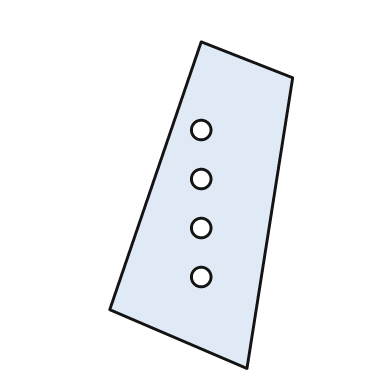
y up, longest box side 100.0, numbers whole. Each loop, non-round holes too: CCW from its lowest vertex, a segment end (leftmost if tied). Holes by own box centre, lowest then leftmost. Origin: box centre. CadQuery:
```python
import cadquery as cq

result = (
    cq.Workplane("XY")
    .moveTo(14.0, -50.0)
    .lineTo(28.0, 39.0)
    .lineTo(0.0, 50.0)
    .lineTo(-28.0, -32.0)
    .close()
    .moveTo(0.0, -22.0)
    .circle(3.0)
    .moveTo(0.0, -7.0)
    .circle(3.0)
    .moveTo(0.0, 8.0)
    .circle(3.0)
    .moveTo(0.0, 23.0)
    .circle(3.0)
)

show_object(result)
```